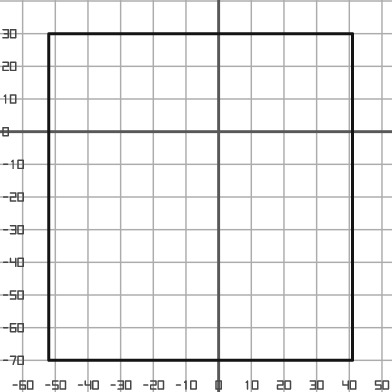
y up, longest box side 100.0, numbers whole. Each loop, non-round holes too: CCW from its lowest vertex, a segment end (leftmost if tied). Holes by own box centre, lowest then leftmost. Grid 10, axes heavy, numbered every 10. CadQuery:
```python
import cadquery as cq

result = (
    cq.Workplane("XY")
    .moveTo(-52.0, -70.0)
    .lineTo(41.0, -70.0)
    .lineTo(41.0, 30.0)
    .lineTo(-52.0, 30.0)
    .close()
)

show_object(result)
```